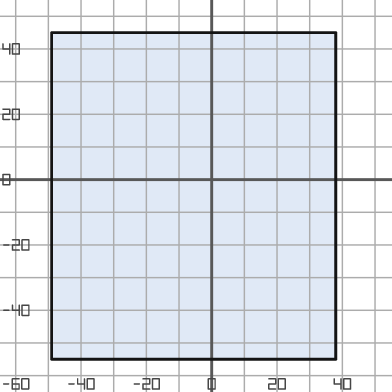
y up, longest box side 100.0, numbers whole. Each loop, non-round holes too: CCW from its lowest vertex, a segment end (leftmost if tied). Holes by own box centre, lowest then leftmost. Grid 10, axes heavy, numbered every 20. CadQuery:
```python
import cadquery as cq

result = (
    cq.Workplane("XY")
    .moveTo(-49.0, -55.0)
    .lineTo(38.0, -55.0)
    .lineTo(38.0, 45.0)
    .lineTo(-49.0, 45.0)
    .close()
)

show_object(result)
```